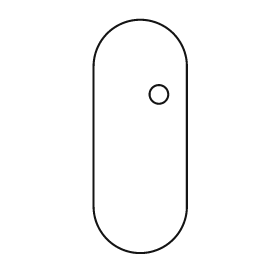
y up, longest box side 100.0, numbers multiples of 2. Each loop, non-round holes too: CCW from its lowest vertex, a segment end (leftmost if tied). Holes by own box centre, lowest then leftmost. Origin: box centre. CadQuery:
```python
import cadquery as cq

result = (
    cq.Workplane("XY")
    .moveTo(-20.0, -30.0)
    .threePointArc((0.0, -50.0), (20.0, -30.0))
    .lineTo(20.0, 30.0)
    .threePointArc((0.0, 50.0), (-20.0, 30.0))
    .close()
    .moveTo(8.0, 18.0)
    .circle(4.0)
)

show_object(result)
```